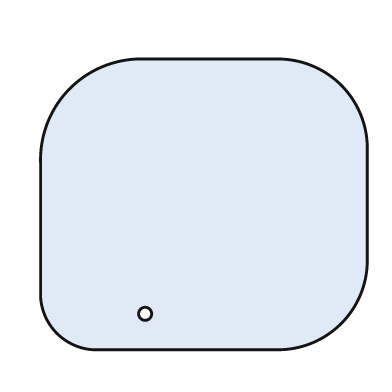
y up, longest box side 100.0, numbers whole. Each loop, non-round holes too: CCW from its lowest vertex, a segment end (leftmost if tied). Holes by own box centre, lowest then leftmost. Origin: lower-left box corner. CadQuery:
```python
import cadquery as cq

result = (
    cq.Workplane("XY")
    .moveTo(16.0, 0.0)
    .lineTo(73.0, 0.0)
    .threePointArc((92.0, 8.0), (100.0, 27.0))
    .lineTo(100.0, 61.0)
    .threePointArc((92.0, 81.0), (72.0, 89.0))
    .lineTo(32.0, 89.0)
    .threePointArc((9.0, 80.0), (0.0, 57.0))
    .lineTo(0.0, 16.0)
    .threePointArc((5.0, 5.0), (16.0, 0.0))
    .close()
    .moveTo(32.0, 11.0)
    .circle(2.0)
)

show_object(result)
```